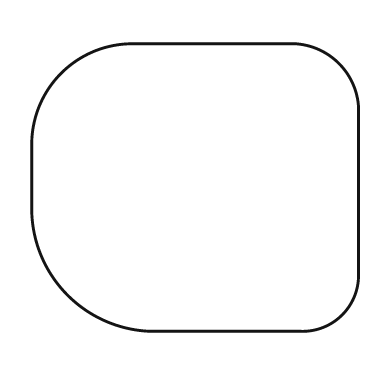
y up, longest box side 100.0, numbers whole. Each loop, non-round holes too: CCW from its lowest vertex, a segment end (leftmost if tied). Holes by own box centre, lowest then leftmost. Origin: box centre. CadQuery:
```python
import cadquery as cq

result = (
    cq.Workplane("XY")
    .moveTo(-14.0, -44.0)
    .lineTo(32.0, -44.0)
    .threePointArc((45.0, -39.0), (50.0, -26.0))
    .lineTo(50.0, 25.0)
    .threePointArc((44.0, 38.0), (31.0, 44.0))
    .lineTo(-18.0, 44.0)
    .threePointArc((-41.0, 35.0), (-50.0, 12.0))
    .lineTo(-50.0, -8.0)
    .threePointArc((-39.0, -33.0), (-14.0, -44.0))
    .close()
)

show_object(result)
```